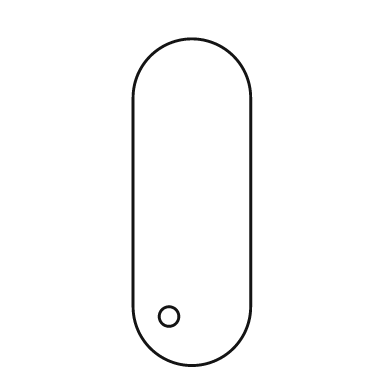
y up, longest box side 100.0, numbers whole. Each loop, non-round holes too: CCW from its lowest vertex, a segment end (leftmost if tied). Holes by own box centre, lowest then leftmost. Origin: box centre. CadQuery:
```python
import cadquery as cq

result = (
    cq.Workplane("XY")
    .moveTo(-18.0, -32.0)
    .threePointArc((0.0, -50.0), (18.0, -32.0))
    .lineTo(18.0, 32.0)
    .threePointArc((0.0, 50.0), (-18.0, 32.0))
    .close()
    .moveTo(-7.0, -35.0)
    .circle(3.0)
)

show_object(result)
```